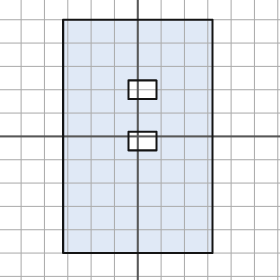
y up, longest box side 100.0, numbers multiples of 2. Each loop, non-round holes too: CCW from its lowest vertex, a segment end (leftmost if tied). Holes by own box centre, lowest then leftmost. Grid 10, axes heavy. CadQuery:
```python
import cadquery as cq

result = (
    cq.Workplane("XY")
    .moveTo(-32.0, -50.0)
    .lineTo(32.0, -50.0)
    .lineTo(32.0, 50.0)
    .lineTo(-32.0, 50.0)
    .close()
    .moveTo(-4.0, -6.0)
    .lineTo(8.0, -6.0)
    .lineTo(8.0, 2.0)
    .lineTo(-4.0, 2.0)
    .close()
    .moveTo(-4.0, 16.0)
    .lineTo(8.0, 16.0)
    .lineTo(8.0, 24.0)
    .lineTo(-4.0, 24.0)
    .close()
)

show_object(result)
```